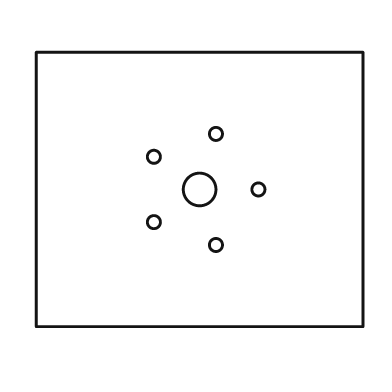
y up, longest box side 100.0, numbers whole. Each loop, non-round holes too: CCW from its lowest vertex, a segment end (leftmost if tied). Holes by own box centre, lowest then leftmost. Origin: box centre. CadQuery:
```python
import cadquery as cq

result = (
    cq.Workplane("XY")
    .moveTo(-50.0, -42.0)
    .lineTo(50.0, -42.0)
    .lineTo(50.0, 42.0)
    .lineTo(-50.0, 42.0)
    .close()
    .moveTo(5.0, -17.0)
    .circle(2.0)
    .moveTo(-14.0, -10.0)
    .circle(2.0)
    .moveTo(0.0, 0.0)
    .circle(5.0)
    .moveTo(18.0, 0.0)
    .circle(2.0)
    .moveTo(-14.0, 10.0)
    .circle(2.0)
    .moveTo(5.0, 17.0)
    .circle(2.0)
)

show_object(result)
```